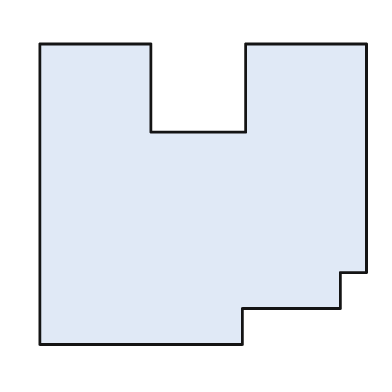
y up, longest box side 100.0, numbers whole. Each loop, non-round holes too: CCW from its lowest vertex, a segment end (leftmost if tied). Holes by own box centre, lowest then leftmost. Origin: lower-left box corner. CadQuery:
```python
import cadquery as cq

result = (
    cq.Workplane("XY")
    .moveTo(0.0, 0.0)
    .lineTo(62.0, 0.0)
    .lineTo(62.0, 11.0)
    .lineTo(92.0, 11.0)
    .lineTo(92.0, 22.0)
    .lineTo(100.0, 22.0)
    .lineTo(100.0, 92.0)
    .lineTo(63.0, 92.0)
    .lineTo(63.0, 65.0)
    .lineTo(34.0, 65.0)
    .lineTo(34.0, 92.0)
    .lineTo(0.0, 92.0)
    .close()
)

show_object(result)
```